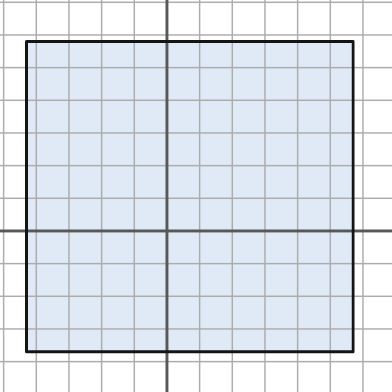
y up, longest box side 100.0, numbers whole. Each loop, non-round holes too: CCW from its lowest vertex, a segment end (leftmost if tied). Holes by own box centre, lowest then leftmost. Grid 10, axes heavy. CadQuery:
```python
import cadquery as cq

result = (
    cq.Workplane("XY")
    .moveTo(-43.0, -37.0)
    .lineTo(57.0, -37.0)
    .lineTo(57.0, 58.0)
    .lineTo(-43.0, 58.0)
    .close()
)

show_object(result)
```